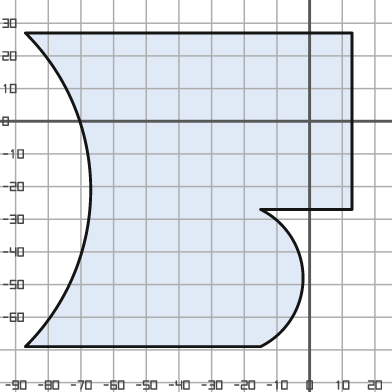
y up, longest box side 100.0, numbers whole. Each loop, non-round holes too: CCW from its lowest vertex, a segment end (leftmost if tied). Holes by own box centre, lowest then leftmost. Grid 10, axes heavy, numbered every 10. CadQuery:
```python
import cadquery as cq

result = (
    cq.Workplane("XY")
    .moveTo(-87.0, -69.0)
    .lineTo(-15.0, -69.0)
    .threePointArc((-2.0, -48.0), (-15.0, -27.0))
    .lineTo(13.0, -27.0)
    .lineTo(13.0, 27.0)
    .lineTo(-87.0, 27.0)
    .threePointArc((-67.0, -21.0), (-87.0, -69.0))
    .close()
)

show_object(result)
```